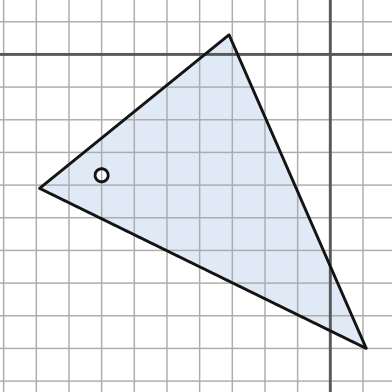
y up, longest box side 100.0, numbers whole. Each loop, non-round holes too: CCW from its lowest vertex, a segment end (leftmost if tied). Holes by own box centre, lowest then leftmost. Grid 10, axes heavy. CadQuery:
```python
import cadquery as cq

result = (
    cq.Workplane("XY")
    .moveTo(11.0, -90.0)
    .lineTo(-31.0, 6.0)
    .lineTo(-89.0, -41.0)
    .close()
    .moveTo(-70.0, -37.0)
    .circle(2.0)
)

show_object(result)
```